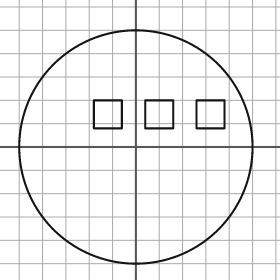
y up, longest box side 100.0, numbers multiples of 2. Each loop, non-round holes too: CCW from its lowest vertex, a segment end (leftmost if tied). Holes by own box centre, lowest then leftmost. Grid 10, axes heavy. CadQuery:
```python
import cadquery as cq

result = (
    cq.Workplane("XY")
    .moveTo(0.0, 0.0)
    .circle(50.0)
    .moveTo(-18.0, 8.0)
    .lineTo(-6.0, 8.0)
    .lineTo(-6.0, 20.0)
    .lineTo(-18.0, 20.0)
    .close()
    .moveTo(4.0, 8.0)
    .lineTo(16.0, 8.0)
    .lineTo(16.0, 20.0)
    .lineTo(4.0, 20.0)
    .close()
    .moveTo(26.0, 8.0)
    .lineTo(38.0, 8.0)
    .lineTo(38.0, 20.0)
    .lineTo(26.0, 20.0)
    .close()
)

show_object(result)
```